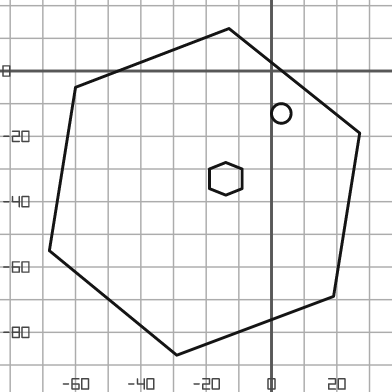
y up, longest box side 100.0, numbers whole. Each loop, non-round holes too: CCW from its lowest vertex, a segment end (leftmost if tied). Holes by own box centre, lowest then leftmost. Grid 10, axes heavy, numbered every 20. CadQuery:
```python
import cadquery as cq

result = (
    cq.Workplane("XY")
    .moveTo(-29.0, -87.0)
    .lineTo(19.0, -69.0)
    .lineTo(27.0, -19.0)
    .lineTo(-13.0, 13.0)
    .lineTo(-60.0, -5.0)
    .lineTo(-68.0, -55.0)
    .close()
    .moveTo(-14.0, -38.0)
    .lineTo(-9.0, -36.0)
    .lineTo(-9.0, -30.0)
    .lineTo(-14.0, -28.0)
    .lineTo(-19.0, -30.0)
    .lineTo(-19.0, -36.0)
    .close()
    .moveTo(3.0, -13.0)
    .circle(3.0)
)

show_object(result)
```